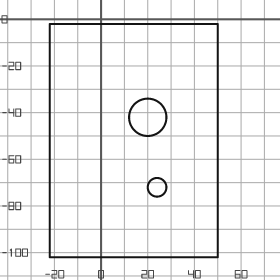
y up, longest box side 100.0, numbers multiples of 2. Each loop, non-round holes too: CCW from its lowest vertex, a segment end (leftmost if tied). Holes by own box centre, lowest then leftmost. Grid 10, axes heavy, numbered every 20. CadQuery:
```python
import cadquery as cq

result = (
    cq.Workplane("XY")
    .moveTo(-22.0, -102.0)
    .lineTo(50.0, -102.0)
    .lineTo(50.0, -2.0)
    .lineTo(-22.0, -2.0)
    .close()
    .moveTo(24.0, -72.0)
    .circle(4.0)
    .moveTo(20.0, -42.0)
    .circle(8.0)
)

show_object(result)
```